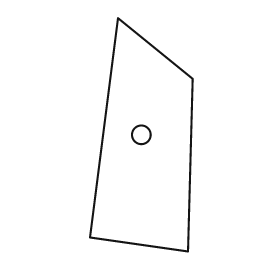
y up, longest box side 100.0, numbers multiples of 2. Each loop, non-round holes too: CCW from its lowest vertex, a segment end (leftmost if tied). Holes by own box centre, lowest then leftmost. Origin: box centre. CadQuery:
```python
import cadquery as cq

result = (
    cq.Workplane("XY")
    .moveTo(20.0, -50.0)
    .lineTo(22.0, 24.0)
    .lineTo(-10.0, 50.0)
    .lineTo(-22.0, -44.0)
    .close()
    .moveTo(0.0, 0.0)
    .circle(4.0)
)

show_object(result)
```